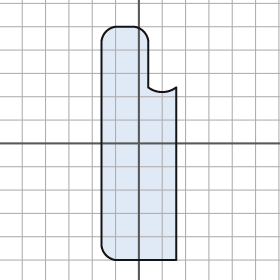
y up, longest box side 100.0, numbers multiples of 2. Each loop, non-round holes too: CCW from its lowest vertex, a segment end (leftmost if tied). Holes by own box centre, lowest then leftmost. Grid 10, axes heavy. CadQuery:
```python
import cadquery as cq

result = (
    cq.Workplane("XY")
    .moveTo(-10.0, -50.0)
    .lineTo(16.0, -50.0)
    .lineTo(16.0, 24.0)
    .threePointArc((10.0, 22.0), (4.0, 24.0))
    .lineTo(4.0, 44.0)
    .threePointArc((2.0, 48.0), (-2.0, 50.0))
    .lineTo(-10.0, 50.0)
    .threePointArc((-14.0, 48.0), (-16.0, 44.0))
    .lineTo(-16.0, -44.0)
    .threePointArc((-14.0, -48.0), (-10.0, -50.0))
    .close()
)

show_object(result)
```